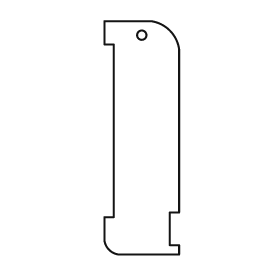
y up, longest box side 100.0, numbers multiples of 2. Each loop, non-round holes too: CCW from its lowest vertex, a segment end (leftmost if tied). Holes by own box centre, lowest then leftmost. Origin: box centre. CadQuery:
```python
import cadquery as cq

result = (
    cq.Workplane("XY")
    .moveTo(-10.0, -50.0)
    .lineTo(16.0, -50.0)
    .lineTo(16.0, -46.0)
    .lineTo(12.0, -46.0)
    .lineTo(12.0, -32.0)
    .lineTo(16.0, -32.0)
    .lineTo(16.0, 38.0)
    .threePointArc((12.0, 46.0), (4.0, 50.0))
    .lineTo(-16.0, 50.0)
    .lineTo(-16.0, 40.0)
    .lineTo(-12.0, 40.0)
    .lineTo(-12.0, -34.0)
    .lineTo(-16.0, -34.0)
    .lineTo(-16.0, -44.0)
    .threePointArc((-14.0, -48.0), (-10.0, -50.0))
    .close()
    .moveTo(0.0, 44.0)
    .circle(2.0)
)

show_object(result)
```